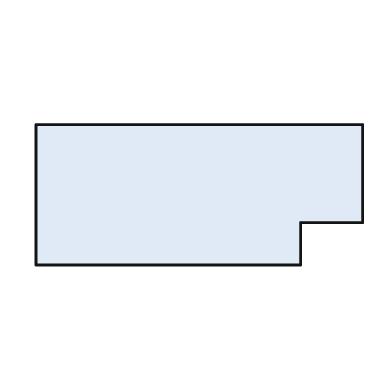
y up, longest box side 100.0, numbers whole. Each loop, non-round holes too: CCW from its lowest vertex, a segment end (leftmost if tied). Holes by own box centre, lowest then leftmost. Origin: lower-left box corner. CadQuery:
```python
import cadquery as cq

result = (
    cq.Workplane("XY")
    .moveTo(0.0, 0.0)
    .lineTo(81.0, 0.0)
    .lineTo(81.0, 13.0)
    .lineTo(100.0, 13.0)
    .lineTo(100.0, 43.0)
    .lineTo(0.0, 43.0)
    .close()
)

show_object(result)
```